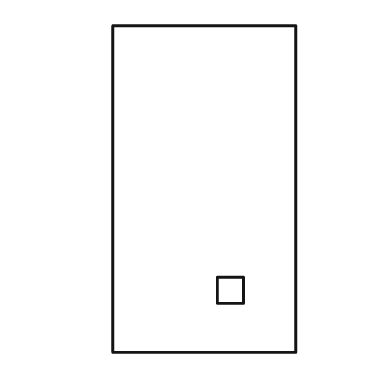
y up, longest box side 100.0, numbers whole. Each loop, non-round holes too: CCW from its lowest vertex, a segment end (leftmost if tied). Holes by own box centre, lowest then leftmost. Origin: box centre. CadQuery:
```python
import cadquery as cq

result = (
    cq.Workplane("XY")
    .moveTo(-28.0, -50.0)
    .lineTo(28.0, -50.0)
    .lineTo(28.0, 50.0)
    .lineTo(-28.0, 50.0)
    .close()
    .moveTo(4.0, -35.0)
    .lineTo(12.0, -35.0)
    .lineTo(12.0, -27.0)
    .lineTo(4.0, -27.0)
    .close()
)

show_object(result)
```